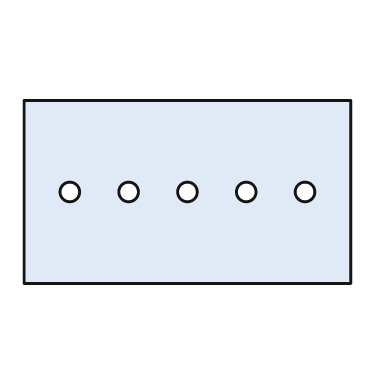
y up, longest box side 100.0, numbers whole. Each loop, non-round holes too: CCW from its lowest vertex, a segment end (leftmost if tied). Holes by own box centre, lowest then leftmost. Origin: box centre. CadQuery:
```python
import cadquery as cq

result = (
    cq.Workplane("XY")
    .moveTo(-50.0, -28.0)
    .lineTo(50.0, -28.0)
    .lineTo(50.0, 28.0)
    .lineTo(-50.0, 28.0)
    .close()
    .moveTo(-36.0, 0.0)
    .circle(3.0)
    .moveTo(-18.0, 0.0)
    .circle(3.0)
    .moveTo(0.0, 0.0)
    .circle(3.0)
    .moveTo(18.0, 0.0)
    .circle(3.0)
    .moveTo(36.0, 0.0)
    .circle(3.0)
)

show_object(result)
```